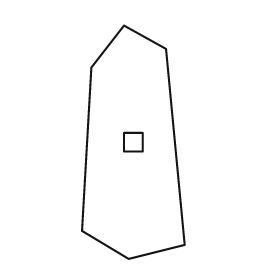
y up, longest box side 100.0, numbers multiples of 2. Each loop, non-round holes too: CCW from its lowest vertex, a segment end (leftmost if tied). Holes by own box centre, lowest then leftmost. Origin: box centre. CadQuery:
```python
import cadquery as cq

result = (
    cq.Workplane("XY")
    .moveTo(-2.0, -50.0)
    .lineTo(22.0, -44.0)
    .lineTo(14.0, 40.0)
    .lineTo(-4.0, 50.0)
    .lineTo(-18.0, 32.0)
    .lineTo(-22.0, -38.0)
    .close()
    .moveTo(-4.0, -4.0)
    .lineTo(4.0, -4.0)
    .lineTo(4.0, 4.0)
    .lineTo(-4.0, 4.0)
    .close()
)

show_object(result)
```